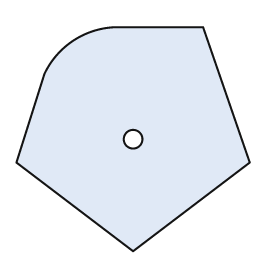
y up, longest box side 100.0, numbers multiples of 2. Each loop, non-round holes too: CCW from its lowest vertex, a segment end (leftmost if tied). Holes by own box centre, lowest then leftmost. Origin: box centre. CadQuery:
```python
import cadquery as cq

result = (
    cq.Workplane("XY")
    .moveTo(0.0, -48.0)
    .lineTo(50.0, -10.0)
    .lineTo(30.0, 48.0)
    .lineTo(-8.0, 48.0)
    .threePointArc((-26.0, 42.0), (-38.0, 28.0))
    .lineTo(-50.0, -10.0)
    .close()
    .moveTo(0.0, 0.0)
    .circle(4.0)
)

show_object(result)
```